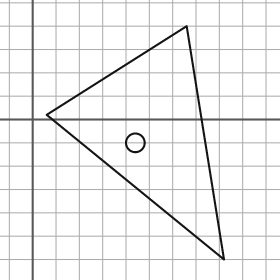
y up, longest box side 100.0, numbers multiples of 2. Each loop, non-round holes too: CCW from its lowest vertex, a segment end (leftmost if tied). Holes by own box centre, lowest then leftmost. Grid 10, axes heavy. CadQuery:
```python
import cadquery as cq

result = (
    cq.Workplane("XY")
    .moveTo(82.0, -60.0)
    .lineTo(66.0, 40.0)
    .lineTo(6.0, 2.0)
    .close()
    .moveTo(44.0, -10.0)
    .circle(4.0)
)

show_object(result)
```